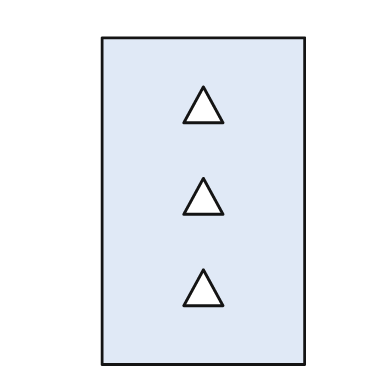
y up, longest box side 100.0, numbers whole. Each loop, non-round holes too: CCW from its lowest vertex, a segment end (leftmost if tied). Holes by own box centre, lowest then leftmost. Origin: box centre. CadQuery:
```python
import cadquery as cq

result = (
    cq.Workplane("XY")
    .moveTo(-31.0, -50.0)
    .lineTo(31.0, -50.0)
    .lineTo(31.0, 50.0)
    .lineTo(-31.0, 50.0)
    .close()
    .moveTo(-6.0, -32.0)
    .lineTo(6.0, -32.0)
    .lineTo(0.0, -21.0)
    .close()
    .moveTo(-6.0, -4.0)
    .lineTo(6.0, -4.0)
    .lineTo(0.0, 7.0)
    .close()
    .moveTo(-6.0, 24.0)
    .lineTo(6.0, 24.0)
    .lineTo(0.0, 35.0)
    .close()
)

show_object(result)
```